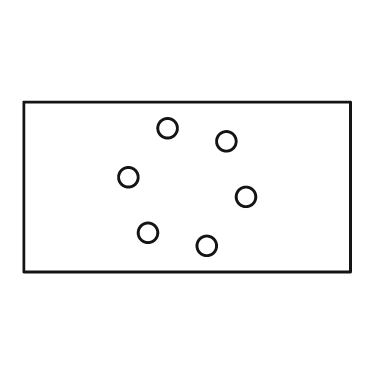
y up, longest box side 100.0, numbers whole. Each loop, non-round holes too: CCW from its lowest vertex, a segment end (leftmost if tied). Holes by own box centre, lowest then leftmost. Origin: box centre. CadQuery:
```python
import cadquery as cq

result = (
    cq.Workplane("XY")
    .moveTo(-50.0, -26.0)
    .lineTo(50.0, -26.0)
    .lineTo(50.0, 26.0)
    .lineTo(-50.0, 26.0)
    .close()
    .moveTo(6.0, -18.0)
    .circle(3.0)
    .moveTo(-12.0, -14.0)
    .circle(3.0)
    .moveTo(18.0, -3.0)
    .circle(3.0)
    .moveTo(-18.0, 3.0)
    .circle(3.0)
    .moveTo(12.0, 14.0)
    .circle(3.0)
    .moveTo(-6.0, 18.0)
    .circle(3.0)
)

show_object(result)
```